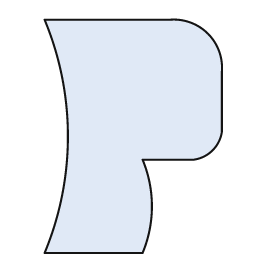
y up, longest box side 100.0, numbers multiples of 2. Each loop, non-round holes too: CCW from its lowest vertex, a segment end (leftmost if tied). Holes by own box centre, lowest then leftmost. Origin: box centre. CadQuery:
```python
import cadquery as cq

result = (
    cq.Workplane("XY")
    .moveTo(-38.0, -50.0)
    .lineTo(4.0, -50.0)
    .threePointArc((8.0, -30.0), (4.0, -10.0))
    .lineTo(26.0, -10.0)
    .threePointArc((34.0, -6.0), (38.0, 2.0))
    .lineTo(38.0, 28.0)
    .threePointArc((32.0, 44.0), (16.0, 50.0))
    .lineTo(-38.0, 50.0)
    .threePointArc((-28.0, 0.0), (-38.0, -50.0))
    .close()
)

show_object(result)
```